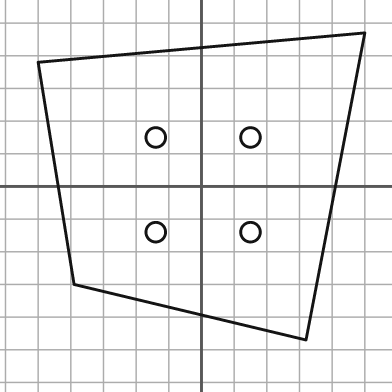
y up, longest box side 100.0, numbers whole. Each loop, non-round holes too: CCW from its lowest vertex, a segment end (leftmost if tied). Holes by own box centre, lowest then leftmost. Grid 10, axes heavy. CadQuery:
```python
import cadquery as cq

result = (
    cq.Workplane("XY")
    .moveTo(32.0, -47.0)
    .lineTo(50.0, 47.0)
    .lineTo(-50.0, 38.0)
    .lineTo(-39.0, -30.0)
    .close()
    .moveTo(-14.0, -14.0)
    .circle(3.0)
    .moveTo(15.0, -14.0)
    .circle(3.0)
    .moveTo(-14.0, 15.0)
    .circle(3.0)
    .moveTo(15.0, 15.0)
    .circle(3.0)
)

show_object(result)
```